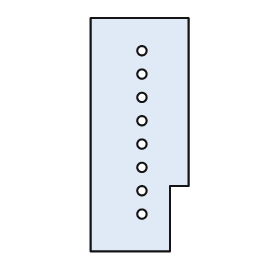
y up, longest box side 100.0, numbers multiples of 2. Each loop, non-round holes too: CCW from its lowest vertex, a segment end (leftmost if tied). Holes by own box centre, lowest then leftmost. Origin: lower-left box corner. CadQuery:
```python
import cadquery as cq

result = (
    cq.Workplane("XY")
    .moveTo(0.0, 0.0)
    .lineTo(34.0, 0.0)
    .lineTo(34.0, 28.0)
    .lineTo(42.0, 28.0)
    .lineTo(42.0, 100.0)
    .lineTo(0.0, 100.0)
    .close()
    .moveTo(22.0, 16.0)
    .circle(2.0)
    .moveTo(22.0, 26.0)
    .circle(2.0)
    .moveTo(22.0, 36.0)
    .circle(2.0)
    .moveTo(22.0, 46.0)
    .circle(2.0)
    .moveTo(22.0, 56.0)
    .circle(2.0)
    .moveTo(22.0, 66.0)
    .circle(2.0)
    .moveTo(22.0, 76.0)
    .circle(2.0)
    .moveTo(22.0, 86.0)
    .circle(2.0)
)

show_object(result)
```